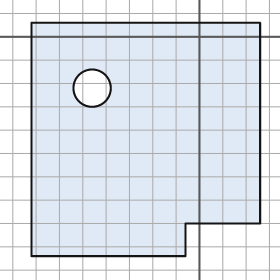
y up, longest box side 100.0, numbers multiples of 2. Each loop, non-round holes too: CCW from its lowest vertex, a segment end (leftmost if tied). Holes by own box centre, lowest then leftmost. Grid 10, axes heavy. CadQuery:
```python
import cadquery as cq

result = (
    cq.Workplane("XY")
    .moveTo(-72.0, -94.0)
    .lineTo(-6.0, -94.0)
    .lineTo(-6.0, -80.0)
    .lineTo(26.0, -80.0)
    .lineTo(26.0, 6.0)
    .lineTo(-72.0, 6.0)
    .close()
    .moveTo(-46.0, -22.0)
    .circle(8.0)
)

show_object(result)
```